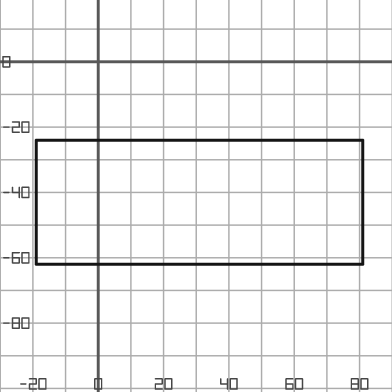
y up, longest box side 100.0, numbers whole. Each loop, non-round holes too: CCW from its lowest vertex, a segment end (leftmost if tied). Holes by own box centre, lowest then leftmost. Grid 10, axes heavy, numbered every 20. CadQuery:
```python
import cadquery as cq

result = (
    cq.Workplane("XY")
    .moveTo(-19.0, -62.0)
    .lineTo(81.0, -62.0)
    .lineTo(81.0, -24.0)
    .lineTo(-19.0, -24.0)
    .close()
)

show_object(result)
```